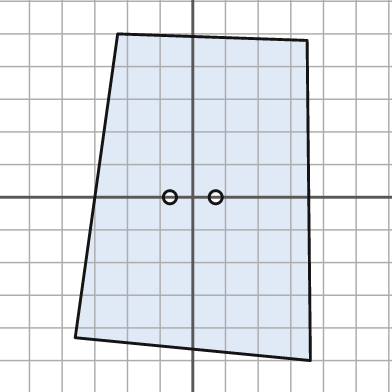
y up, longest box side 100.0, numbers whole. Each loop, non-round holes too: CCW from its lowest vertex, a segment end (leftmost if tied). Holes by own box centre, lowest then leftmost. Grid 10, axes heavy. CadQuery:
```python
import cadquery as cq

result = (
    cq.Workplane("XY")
    .moveTo(36.0, -50.0)
    .lineTo(35.0, 48.0)
    .lineTo(-23.0, 50.0)
    .lineTo(-36.0, -43.0)
    .close()
    .moveTo(-7.0, 0.0)
    .circle(2.0)
    .moveTo(7.0, 0.0)
    .circle(2.0)
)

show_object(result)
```